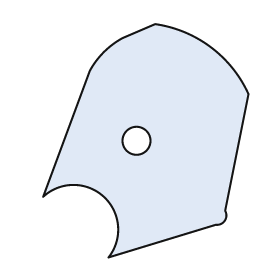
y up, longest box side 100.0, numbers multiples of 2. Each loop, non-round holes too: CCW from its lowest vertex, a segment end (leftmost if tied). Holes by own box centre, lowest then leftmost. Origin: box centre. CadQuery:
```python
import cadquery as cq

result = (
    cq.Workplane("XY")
    .moveTo(-16.0, -50.0)
    .lineTo(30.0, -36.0)
    .threePointArc((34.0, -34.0), (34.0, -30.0))
    .lineTo(44.0, 20.0)
    .threePointArc((28.0, 40.0), (4.0, 50.0))
    .lineTo(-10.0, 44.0)
    .threePointArc((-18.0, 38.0), (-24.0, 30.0))
    .lineTo(-44.0, -24.0)
    .threePointArc((-18.0, -24.0), (-16.0, -50.0))
    .close()
    .moveTo(-4.0, 0.0)
    .circle(6.0)
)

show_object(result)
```